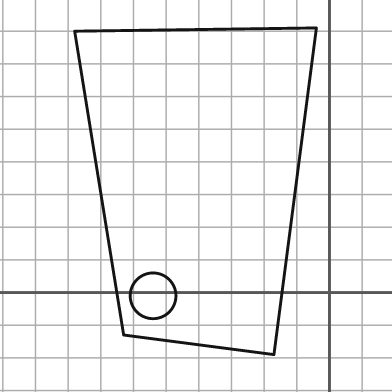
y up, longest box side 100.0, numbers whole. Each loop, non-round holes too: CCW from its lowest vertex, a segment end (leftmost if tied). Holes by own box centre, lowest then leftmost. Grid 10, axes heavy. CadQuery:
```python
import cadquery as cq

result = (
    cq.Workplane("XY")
    .moveTo(-17.0, -19.0)
    .lineTo(-4.0, 81.0)
    .lineTo(-78.0, 80.0)
    .lineTo(-63.0, -13.0)
    .close()
    .moveTo(-54.0, -1.0)
    .circle(7.0)
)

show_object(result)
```